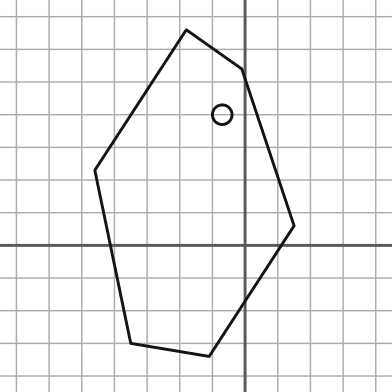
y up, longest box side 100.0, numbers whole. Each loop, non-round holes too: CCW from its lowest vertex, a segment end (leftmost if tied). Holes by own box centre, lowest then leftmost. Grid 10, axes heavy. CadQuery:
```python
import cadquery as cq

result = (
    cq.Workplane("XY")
    .moveTo(-11.0, -34.0)
    .lineTo(15.0, 6.0)
    .lineTo(-1.0, 54.0)
    .lineTo(-18.0, 66.0)
    .lineTo(-46.0, 23.0)
    .lineTo(-35.0, -30.0)
    .close()
    .moveTo(-7.0, 40.0)
    .circle(3.0)
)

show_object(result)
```